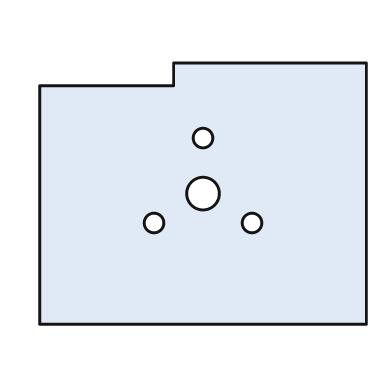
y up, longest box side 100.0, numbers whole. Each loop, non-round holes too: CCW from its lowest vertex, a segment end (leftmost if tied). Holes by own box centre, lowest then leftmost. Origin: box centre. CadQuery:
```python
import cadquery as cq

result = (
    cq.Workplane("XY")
    .moveTo(-50.0, -40.0)
    .lineTo(50.0, -40.0)
    .lineTo(50.0, 40.0)
    .lineTo(-9.0, 40.0)
    .lineTo(-9.0, 33.0)
    .lineTo(-50.0, 33.0)
    .close()
    .moveTo(-15.0, -9.0)
    .circle(3.0)
    .moveTo(15.0, -9.0)
    .circle(3.0)
    .moveTo(0.0, 0.0)
    .circle(5.0)
    .moveTo(0.0, 17.0)
    .circle(3.0)
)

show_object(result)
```